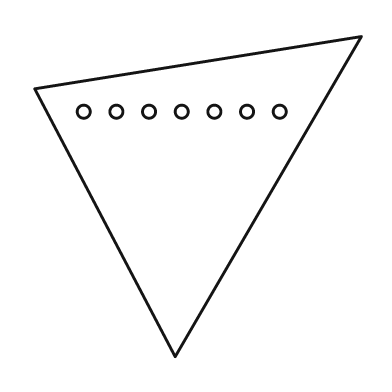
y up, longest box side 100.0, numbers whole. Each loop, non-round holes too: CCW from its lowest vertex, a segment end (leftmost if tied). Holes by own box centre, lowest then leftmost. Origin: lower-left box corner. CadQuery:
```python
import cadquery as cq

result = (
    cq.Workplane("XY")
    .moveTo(43.0, 0.0)
    .lineTo(100.0, 98.0)
    .lineTo(0.0, 82.0)
    .close()
    .moveTo(15.0, 75.0)
    .circle(2.0)
    .moveTo(25.0, 75.0)
    .circle(2.0)
    .moveTo(35.0, 75.0)
    .circle(2.0)
    .moveTo(45.0, 75.0)
    .circle(2.0)
    .moveTo(55.0, 75.0)
    .circle(2.0)
    .moveTo(65.0, 75.0)
    .circle(2.0)
    .moveTo(75.0, 75.0)
    .circle(2.0)
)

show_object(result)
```